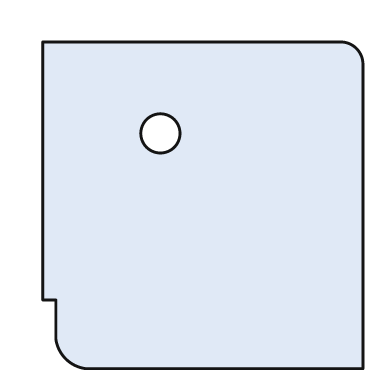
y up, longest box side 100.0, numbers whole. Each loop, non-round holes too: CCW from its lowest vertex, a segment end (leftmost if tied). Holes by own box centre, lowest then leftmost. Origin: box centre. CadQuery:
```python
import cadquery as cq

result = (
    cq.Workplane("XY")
    .moveTo(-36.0, -50.0)
    .lineTo(49.0, -50.0)
    .lineTo(49.0, 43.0)
    .threePointArc((47.0, 48.0), (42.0, 50.0))
    .lineTo(-49.0, 50.0)
    .lineTo(-49.0, -29.0)
    .lineTo(-45.0, -29.0)
    .lineTo(-45.0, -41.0)
    .threePointArc((-42.0, -47.0), (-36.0, -50.0))
    .close()
    .moveTo(-13.0, 22.0)
    .circle(6.0)
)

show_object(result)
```